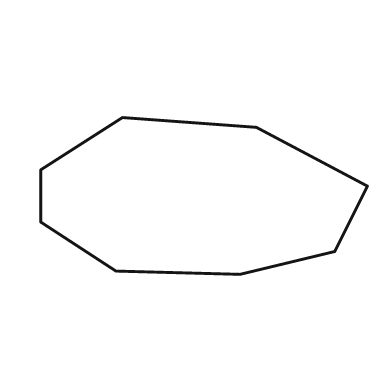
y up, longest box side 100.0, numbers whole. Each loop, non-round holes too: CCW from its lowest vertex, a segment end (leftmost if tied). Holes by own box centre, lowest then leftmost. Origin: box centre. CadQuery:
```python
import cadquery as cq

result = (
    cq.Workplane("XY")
    .moveTo(11.0, -24.0)
    .lineTo(40.0, -17.0)
    .lineTo(50.0, 3.0)
    .lineTo(16.0, 21.0)
    .lineTo(-25.0, 24.0)
    .lineTo(-50.0, 8.0)
    .lineTo(-50.0, -8.0)
    .lineTo(-27.0, -23.0)
    .close()
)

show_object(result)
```